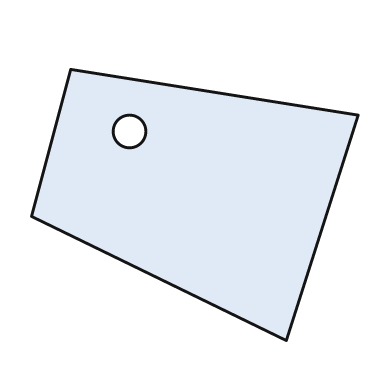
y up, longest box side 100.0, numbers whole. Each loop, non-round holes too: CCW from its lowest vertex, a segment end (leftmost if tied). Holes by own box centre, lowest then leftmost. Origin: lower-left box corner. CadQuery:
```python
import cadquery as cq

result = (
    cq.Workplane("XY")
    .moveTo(78.0, 0.0)
    .lineTo(100.0, 69.0)
    .lineTo(12.0, 83.0)
    .lineTo(0.0, 38.0)
    .close()
    .moveTo(30.0, 64.0)
    .circle(5.0)
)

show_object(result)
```